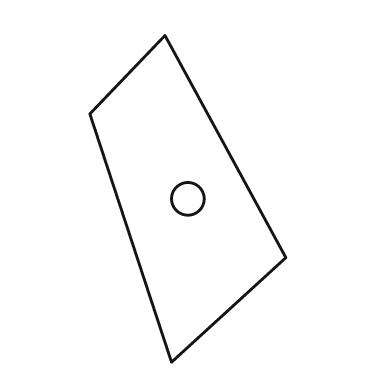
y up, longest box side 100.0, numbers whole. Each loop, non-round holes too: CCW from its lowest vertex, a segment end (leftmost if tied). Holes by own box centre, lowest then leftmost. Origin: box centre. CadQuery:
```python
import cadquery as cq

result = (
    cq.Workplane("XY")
    .moveTo(-5.0, -50.0)
    .lineTo(30.0, -18.0)
    .lineTo(-7.0, 50.0)
    .lineTo(-30.0, 26.0)
    .close()
    .moveTo(0.0, 0.0)
    .circle(5.0)
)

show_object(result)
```